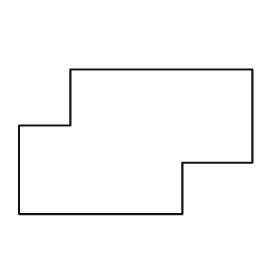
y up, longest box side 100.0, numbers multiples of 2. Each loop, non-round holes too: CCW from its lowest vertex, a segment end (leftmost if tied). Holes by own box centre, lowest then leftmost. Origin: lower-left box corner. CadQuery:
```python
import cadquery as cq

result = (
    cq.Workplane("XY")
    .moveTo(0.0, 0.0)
    .lineTo(70.0, 0.0)
    .lineTo(70.0, 22.0)
    .lineTo(100.0, 22.0)
    .lineTo(100.0, 62.0)
    .lineTo(22.0, 62.0)
    .lineTo(22.0, 38.0)
    .lineTo(0.0, 38.0)
    .close()
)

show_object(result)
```